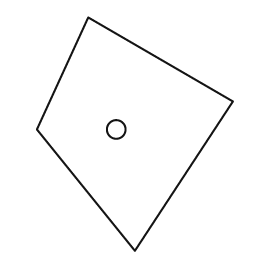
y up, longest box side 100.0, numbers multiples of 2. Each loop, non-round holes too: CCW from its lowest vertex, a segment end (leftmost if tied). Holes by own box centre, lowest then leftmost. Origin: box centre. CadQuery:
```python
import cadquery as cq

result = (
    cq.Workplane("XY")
    .moveTo(0.0, -50.0)
    .lineTo(42.0, 14.0)
    .lineTo(-20.0, 50.0)
    .lineTo(-42.0, 2.0)
    .close()
    .moveTo(-8.0, 2.0)
    .circle(4.0)
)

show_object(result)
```